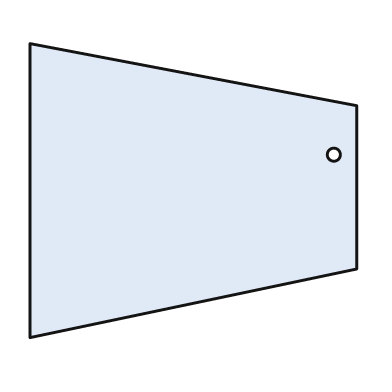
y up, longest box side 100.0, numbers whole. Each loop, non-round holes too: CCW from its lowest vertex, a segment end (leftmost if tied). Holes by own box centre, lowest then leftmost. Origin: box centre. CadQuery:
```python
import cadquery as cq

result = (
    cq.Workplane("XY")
    .moveTo(-50.0, -45.0)
    .lineTo(50.0, -24.0)
    .lineTo(50.0, 26.0)
    .lineTo(-50.0, 45.0)
    .close()
    .moveTo(43.0, 11.0)
    .circle(2.0)
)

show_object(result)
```